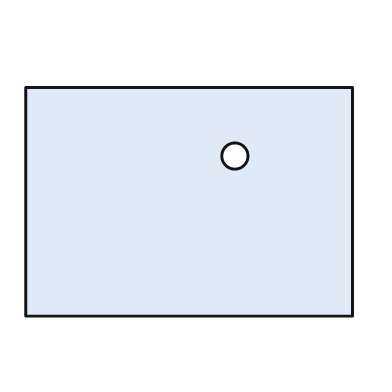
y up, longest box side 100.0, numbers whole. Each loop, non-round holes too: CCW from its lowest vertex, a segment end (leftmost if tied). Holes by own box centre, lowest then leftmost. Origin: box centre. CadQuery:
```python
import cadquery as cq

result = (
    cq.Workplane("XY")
    .moveTo(-50.0, -35.0)
    .lineTo(50.0, -35.0)
    .lineTo(50.0, 35.0)
    .lineTo(-50.0, 35.0)
    .close()
    .moveTo(14.0, 14.0)
    .circle(4.0)
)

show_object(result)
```